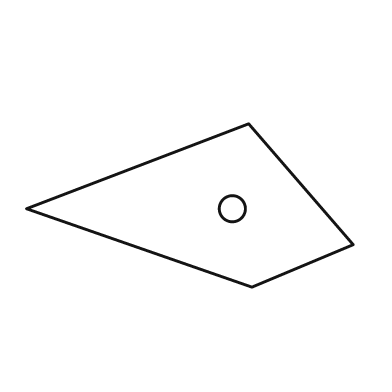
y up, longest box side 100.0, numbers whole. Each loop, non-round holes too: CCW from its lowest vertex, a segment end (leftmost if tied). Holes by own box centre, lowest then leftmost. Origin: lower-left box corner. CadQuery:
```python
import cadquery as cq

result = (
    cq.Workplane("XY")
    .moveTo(69.0, 0.0)
    .lineTo(100.0, 13.0)
    .lineTo(68.0, 50.0)
    .lineTo(0.0, 24.0)
    .close()
    .moveTo(63.0, 24.0)
    .circle(4.0)
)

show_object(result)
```